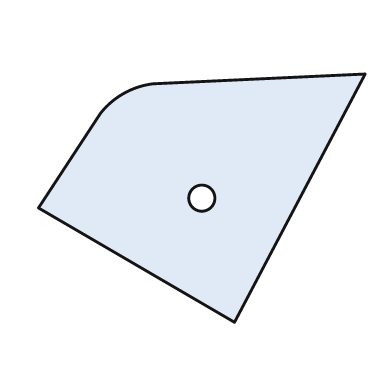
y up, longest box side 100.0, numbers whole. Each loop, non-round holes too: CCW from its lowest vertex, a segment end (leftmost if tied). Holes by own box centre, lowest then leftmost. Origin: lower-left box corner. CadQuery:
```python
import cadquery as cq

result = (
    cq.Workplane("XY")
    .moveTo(60.0, 0.0)
    .lineTo(100.0, 76.0)
    .lineTo(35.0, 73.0)
    .threePointArc((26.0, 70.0), (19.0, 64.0))
    .lineTo(0.0, 35.0)
    .close()
    .moveTo(50.0, 38.0)
    .circle(4.0)
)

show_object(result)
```